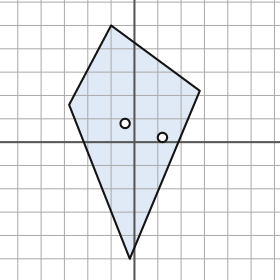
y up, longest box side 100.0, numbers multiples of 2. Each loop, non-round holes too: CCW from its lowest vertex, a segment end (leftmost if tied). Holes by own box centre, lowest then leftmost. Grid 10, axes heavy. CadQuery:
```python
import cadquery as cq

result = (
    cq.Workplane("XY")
    .moveTo(-2.0, -50.0)
    .lineTo(28.0, 22.0)
    .lineTo(-10.0, 50.0)
    .lineTo(-28.0, 16.0)
    .close()
    .moveTo(12.0, 2.0)
    .circle(2.0)
    .moveTo(-4.0, 8.0)
    .circle(2.0)
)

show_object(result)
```